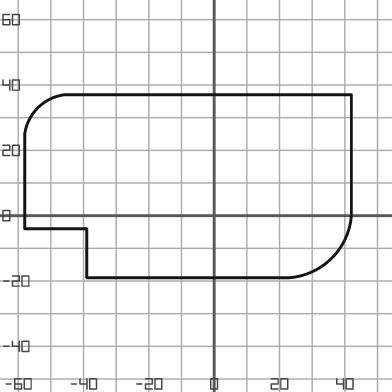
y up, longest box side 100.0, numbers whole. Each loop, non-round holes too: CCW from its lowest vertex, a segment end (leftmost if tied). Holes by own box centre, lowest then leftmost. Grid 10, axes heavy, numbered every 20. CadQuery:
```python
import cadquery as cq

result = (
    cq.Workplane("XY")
    .moveTo(-39.0, -19.0)
    .lineTo(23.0, -19.0)
    .threePointArc((36.0, -13.0), (42.0, 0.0))
    .lineTo(42.0, 37.0)
    .lineTo(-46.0, 37.0)
    .threePointArc((-54.0, 33.0), (-58.0, 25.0))
    .lineTo(-58.0, -4.0)
    .lineTo(-39.0, -4.0)
    .close()
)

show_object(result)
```